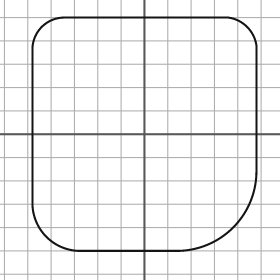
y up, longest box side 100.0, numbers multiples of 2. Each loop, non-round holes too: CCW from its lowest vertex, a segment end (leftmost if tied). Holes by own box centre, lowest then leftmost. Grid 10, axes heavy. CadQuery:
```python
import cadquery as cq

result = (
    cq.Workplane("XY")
    .moveTo(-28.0, -50.0)
    .lineTo(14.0, -50.0)
    .threePointArc((38.0, -40.0), (48.0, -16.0))
    .lineTo(48.0, 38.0)
    .threePointArc((44.0, 46.0), (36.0, 50.0))
    .lineTo(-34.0, 50.0)
    .threePointArc((-44.0, 46.0), (-48.0, 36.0))
    .lineTo(-48.0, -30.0)
    .threePointArc((-42.0, -44.0), (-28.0, -50.0))
    .close()
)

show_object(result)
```